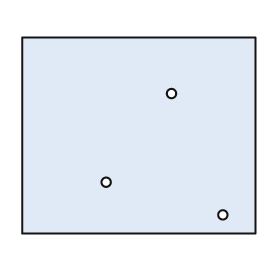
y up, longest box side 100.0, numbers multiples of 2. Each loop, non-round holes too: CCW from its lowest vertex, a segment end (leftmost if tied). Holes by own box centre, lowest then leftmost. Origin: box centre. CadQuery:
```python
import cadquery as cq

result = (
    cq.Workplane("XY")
    .moveTo(-50.0, -42.0)
    .lineTo(50.0, -42.0)
    .lineTo(50.0, 42.0)
    .lineTo(-50.0, 42.0)
    .close()
    .moveTo(36.0, -34.0)
    .circle(2.0)
    .moveTo(-14.0, -20.0)
    .circle(2.0)
    .moveTo(14.0, 18.0)
    .circle(2.0)
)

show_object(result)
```